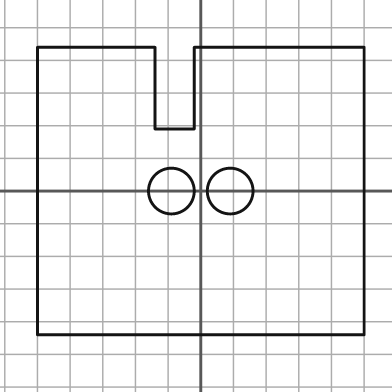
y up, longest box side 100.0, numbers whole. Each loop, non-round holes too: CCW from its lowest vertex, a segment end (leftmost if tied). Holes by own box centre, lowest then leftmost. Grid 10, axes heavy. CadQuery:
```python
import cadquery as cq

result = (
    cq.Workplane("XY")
    .moveTo(-50.0, -44.0)
    .lineTo(50.0, -44.0)
    .lineTo(50.0, 44.0)
    .lineTo(-2.0, 44.0)
    .lineTo(-2.0, 19.0)
    .lineTo(-14.0, 19.0)
    .lineTo(-14.0, 44.0)
    .lineTo(-50.0, 44.0)
    .close()
    .moveTo(-9.0, 0.0)
    .circle(7.0)
    .moveTo(9.0, 0.0)
    .circle(7.0)
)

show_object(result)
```